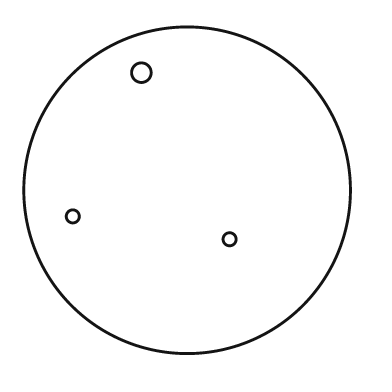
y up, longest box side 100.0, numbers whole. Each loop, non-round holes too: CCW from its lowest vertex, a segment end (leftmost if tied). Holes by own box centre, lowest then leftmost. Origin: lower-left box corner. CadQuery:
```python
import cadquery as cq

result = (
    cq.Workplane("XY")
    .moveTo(50.0, 50.0)
    .circle(50.0)
    .moveTo(63.0, 35.0)
    .circle(2.0)
    .moveTo(15.0, 42.0)
    .circle(2.0)
    .moveTo(36.0, 86.0)
    .circle(3.0)
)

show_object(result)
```